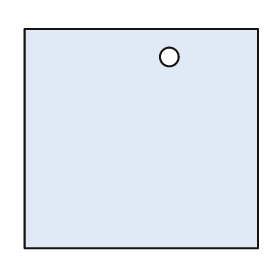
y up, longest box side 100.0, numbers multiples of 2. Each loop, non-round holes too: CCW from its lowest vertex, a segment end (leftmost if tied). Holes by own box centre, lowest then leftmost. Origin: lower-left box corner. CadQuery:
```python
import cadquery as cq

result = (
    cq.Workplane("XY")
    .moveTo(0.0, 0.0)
    .lineTo(100.0, 0.0)
    .lineTo(100.0, 94.0)
    .lineTo(0.0, 94.0)
    .close()
    .moveTo(62.0, 82.0)
    .circle(4.0)
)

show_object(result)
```